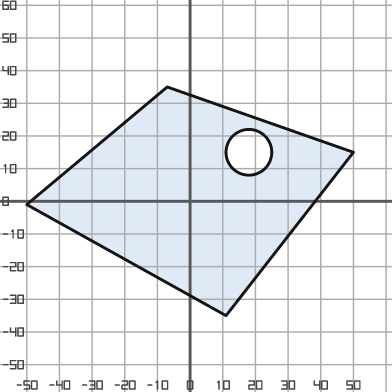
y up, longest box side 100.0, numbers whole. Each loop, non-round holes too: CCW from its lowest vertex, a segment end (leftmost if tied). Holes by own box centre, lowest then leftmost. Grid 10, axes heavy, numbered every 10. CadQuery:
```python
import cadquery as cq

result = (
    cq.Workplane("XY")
    .moveTo(11.0, -35.0)
    .lineTo(50.0, 15.0)
    .lineTo(-7.0, 35.0)
    .lineTo(-50.0, -1.0)
    .close()
    .moveTo(18.0, 15.0)
    .circle(7.0)
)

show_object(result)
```